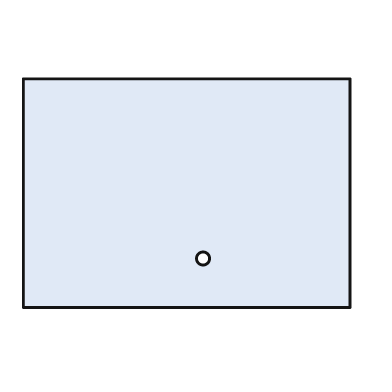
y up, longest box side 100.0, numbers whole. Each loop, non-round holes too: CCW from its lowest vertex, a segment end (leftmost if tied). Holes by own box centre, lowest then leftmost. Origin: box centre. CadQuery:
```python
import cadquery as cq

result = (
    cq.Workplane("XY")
    .moveTo(-50.0, -35.0)
    .lineTo(50.0, -35.0)
    .lineTo(50.0, 35.0)
    .lineTo(-50.0, 35.0)
    .close()
    .moveTo(5.0, -20.0)
    .circle(2.0)
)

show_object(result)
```